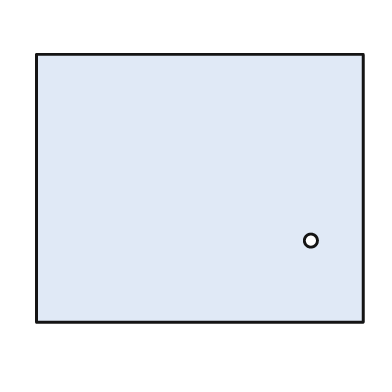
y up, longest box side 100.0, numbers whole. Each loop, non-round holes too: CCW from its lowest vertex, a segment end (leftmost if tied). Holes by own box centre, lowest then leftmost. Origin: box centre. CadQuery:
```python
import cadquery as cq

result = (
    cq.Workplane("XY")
    .moveTo(-50.0, -41.0)
    .lineTo(50.0, -41.0)
    .lineTo(50.0, 41.0)
    .lineTo(-50.0, 41.0)
    .close()
    .moveTo(34.0, -16.0)
    .circle(2.0)
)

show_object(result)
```